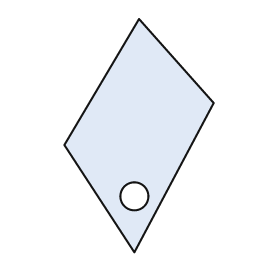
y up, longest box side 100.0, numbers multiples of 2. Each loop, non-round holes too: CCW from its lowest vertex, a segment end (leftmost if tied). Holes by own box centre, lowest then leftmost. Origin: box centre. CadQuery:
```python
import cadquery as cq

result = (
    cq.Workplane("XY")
    .moveTo(-2.0, -50.0)
    .lineTo(32.0, 14.0)
    .lineTo(0.0, 50.0)
    .lineTo(-32.0, -4.0)
    .close()
    .moveTo(-2.0, -26.0)
    .circle(6.0)
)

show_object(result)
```